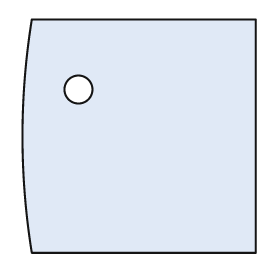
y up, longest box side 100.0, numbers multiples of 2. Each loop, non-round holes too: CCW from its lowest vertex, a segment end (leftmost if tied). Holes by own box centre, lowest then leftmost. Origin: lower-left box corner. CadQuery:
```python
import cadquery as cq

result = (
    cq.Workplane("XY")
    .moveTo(4.0, 0.0)
    .lineTo(100.0, 0.0)
    .lineTo(100.0, 100.0)
    .lineTo(4.0, 100.0)
    .threePointArc((0.0, 50.0), (4.0, 0.0))
    .close()
    .moveTo(24.0, 70.0)
    .circle(6.0)
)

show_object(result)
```